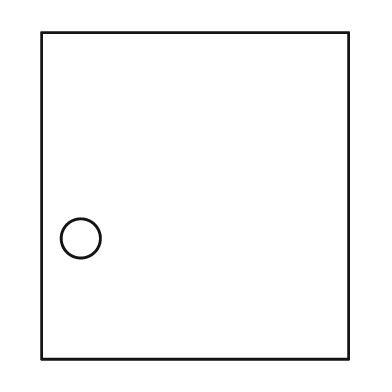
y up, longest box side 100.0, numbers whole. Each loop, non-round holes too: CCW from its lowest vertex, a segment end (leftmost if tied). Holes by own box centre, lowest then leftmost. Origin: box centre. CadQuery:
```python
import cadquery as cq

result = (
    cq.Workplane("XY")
    .moveTo(-47.0, -50.0)
    .lineTo(47.0, -50.0)
    .lineTo(47.0, 50.0)
    .lineTo(-47.0, 50.0)
    .close()
    .moveTo(-35.0, -13.0)
    .circle(6.0)
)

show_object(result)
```